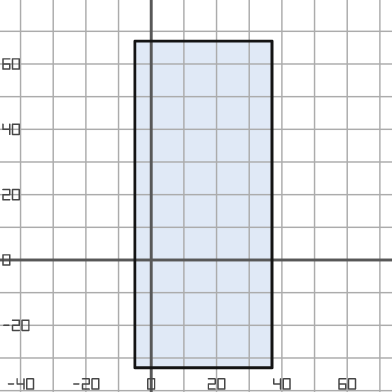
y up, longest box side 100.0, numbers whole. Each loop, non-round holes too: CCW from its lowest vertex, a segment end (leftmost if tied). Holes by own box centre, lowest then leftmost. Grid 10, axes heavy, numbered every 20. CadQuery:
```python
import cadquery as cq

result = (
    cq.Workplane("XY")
    .moveTo(-5.0, -33.0)
    .lineTo(37.0, -33.0)
    .lineTo(37.0, 67.0)
    .lineTo(-5.0, 67.0)
    .close()
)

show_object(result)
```